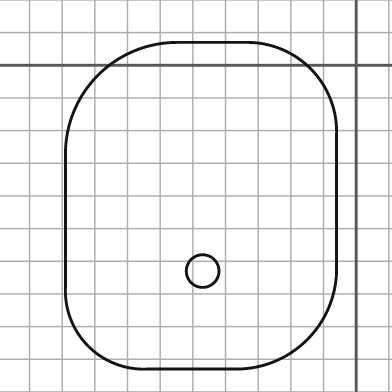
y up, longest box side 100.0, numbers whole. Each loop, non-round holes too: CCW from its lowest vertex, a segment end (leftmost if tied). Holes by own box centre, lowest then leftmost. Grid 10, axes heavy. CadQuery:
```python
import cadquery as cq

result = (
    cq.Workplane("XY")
    .moveTo(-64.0, -93.0)
    .lineTo(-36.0, -93.0)
    .threePointArc((-15.0, -84.0), (-6.0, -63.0))
    .lineTo(-6.0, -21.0)
    .threePointArc((-14.0, -1.0), (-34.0, 7.0))
    .lineTo(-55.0, 7.0)
    .threePointArc((-79.0, -3.0), (-89.0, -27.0))
    .lineTo(-89.0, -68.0)
    .threePointArc((-82.0, -86.0), (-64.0, -93.0))
    .close()
    .moveTo(-47.0, -63.0)
    .circle(5.0)
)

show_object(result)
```